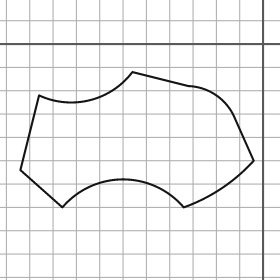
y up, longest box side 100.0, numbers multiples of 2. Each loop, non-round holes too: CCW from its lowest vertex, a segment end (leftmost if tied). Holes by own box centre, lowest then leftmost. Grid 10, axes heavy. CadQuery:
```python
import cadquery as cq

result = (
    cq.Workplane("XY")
    .moveTo(-86.0, -70.0)
    .threePointArc((-60.0, -58.0), (-34.0, -70.0))
    .threePointArc((-18.0, -62.0), (-4.0, -50.0))
    .lineTo(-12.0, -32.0)
    .threePointArc((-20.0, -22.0), (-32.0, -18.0))
    .lineTo(-56.0, -12.0)
    .threePointArc((-74.0, -24.0), (-96.0, -22.0))
    .lineTo(-104.0, -54.0)
    .close()
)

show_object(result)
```